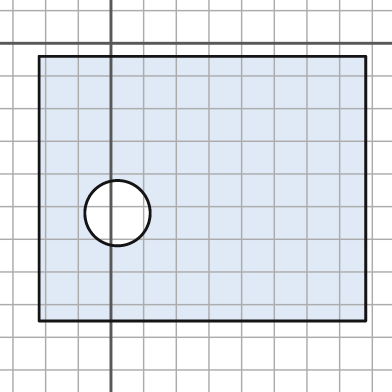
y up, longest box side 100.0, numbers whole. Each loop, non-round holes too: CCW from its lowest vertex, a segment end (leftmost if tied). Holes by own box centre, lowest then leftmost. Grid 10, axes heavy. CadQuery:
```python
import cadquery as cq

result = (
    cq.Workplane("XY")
    .moveTo(-22.0, -85.0)
    .lineTo(78.0, -85.0)
    .lineTo(78.0, -4.0)
    .lineTo(-22.0, -4.0)
    .close()
    .moveTo(2.0, -52.0)
    .circle(10.0)
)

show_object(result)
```